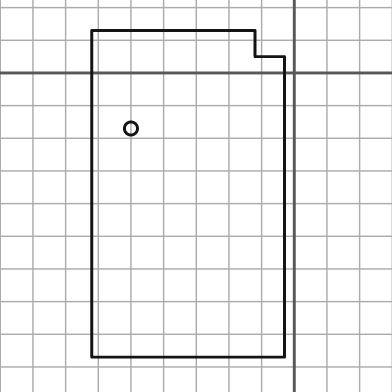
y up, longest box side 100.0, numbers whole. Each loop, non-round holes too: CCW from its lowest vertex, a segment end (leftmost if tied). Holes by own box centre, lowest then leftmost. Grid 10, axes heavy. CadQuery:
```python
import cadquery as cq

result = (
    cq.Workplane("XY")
    .moveTo(-62.0, -87.0)
    .lineTo(-3.0, -87.0)
    .lineTo(-3.0, 5.0)
    .lineTo(-12.0, 5.0)
    .lineTo(-12.0, 13.0)
    .lineTo(-62.0, 13.0)
    .close()
    .moveTo(-50.0, -17.0)
    .circle(2.0)
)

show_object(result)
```